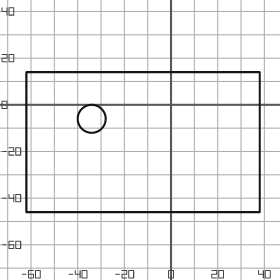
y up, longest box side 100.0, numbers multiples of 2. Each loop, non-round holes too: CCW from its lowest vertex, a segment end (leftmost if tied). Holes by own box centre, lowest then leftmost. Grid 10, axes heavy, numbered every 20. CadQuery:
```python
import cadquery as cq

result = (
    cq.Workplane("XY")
    .moveTo(-62.0, -46.0)
    .lineTo(38.0, -46.0)
    .lineTo(38.0, 14.0)
    .lineTo(-62.0, 14.0)
    .close()
    .moveTo(-34.0, -6.0)
    .circle(6.0)
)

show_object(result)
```